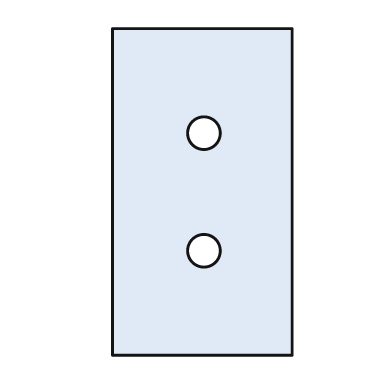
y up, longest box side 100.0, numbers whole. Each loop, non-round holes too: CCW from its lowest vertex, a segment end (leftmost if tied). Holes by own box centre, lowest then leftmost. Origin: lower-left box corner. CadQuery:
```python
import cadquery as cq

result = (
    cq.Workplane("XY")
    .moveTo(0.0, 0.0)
    .lineTo(55.0, 0.0)
    .lineTo(55.0, 100.0)
    .lineTo(0.0, 100.0)
    .close()
    .moveTo(28.0, 32.0)
    .circle(5.0)
    .moveTo(28.0, 68.0)
    .circle(5.0)
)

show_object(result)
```